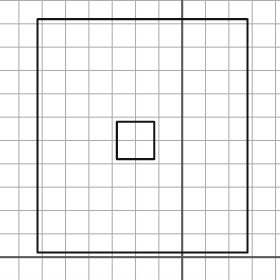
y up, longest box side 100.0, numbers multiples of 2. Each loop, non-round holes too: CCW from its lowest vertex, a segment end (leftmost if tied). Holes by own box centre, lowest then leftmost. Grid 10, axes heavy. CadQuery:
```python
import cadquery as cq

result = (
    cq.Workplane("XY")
    .moveTo(-62.0, 2.0)
    .lineTo(28.0, 2.0)
    .lineTo(28.0, 102.0)
    .lineTo(-62.0, 102.0)
    .close()
    .moveTo(-28.0, 42.0)
    .lineTo(-12.0, 42.0)
    .lineTo(-12.0, 58.0)
    .lineTo(-28.0, 58.0)
    .close()
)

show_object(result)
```